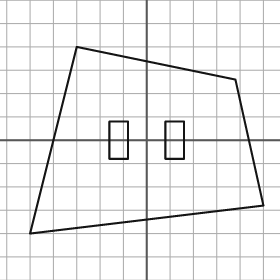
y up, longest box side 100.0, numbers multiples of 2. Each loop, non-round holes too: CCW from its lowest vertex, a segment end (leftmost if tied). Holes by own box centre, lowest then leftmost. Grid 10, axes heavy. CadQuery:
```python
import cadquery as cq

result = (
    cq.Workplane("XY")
    .moveTo(-50.0, -40.0)
    .lineTo(50.0, -28.0)
    .lineTo(38.0, 26.0)
    .lineTo(-30.0, 40.0)
    .close()
    .moveTo(-16.0, -8.0)
    .lineTo(-8.0, -8.0)
    .lineTo(-8.0, 8.0)
    .lineTo(-16.0, 8.0)
    .close()
    .moveTo(8.0, -8.0)
    .lineTo(16.0, -8.0)
    .lineTo(16.0, 8.0)
    .lineTo(8.0, 8.0)
    .close()
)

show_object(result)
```